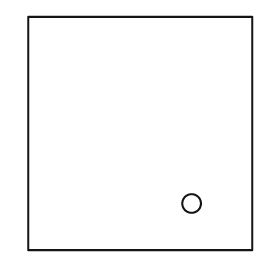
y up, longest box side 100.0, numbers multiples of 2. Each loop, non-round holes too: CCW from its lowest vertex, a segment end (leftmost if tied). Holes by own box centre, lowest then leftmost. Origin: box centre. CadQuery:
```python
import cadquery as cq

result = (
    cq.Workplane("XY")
    .moveTo(-48.0, -50.0)
    .lineTo(48.0, -50.0)
    .lineTo(48.0, 50.0)
    .lineTo(-48.0, 50.0)
    .close()
    .moveTo(22.0, -30.0)
    .circle(4.0)
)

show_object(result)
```